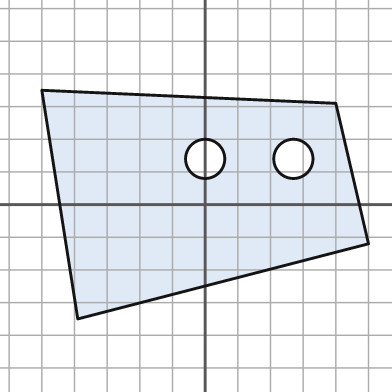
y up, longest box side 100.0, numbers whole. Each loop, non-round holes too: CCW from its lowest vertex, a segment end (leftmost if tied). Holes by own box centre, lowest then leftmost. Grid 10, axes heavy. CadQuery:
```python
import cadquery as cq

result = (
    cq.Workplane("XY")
    .moveTo(-39.0, -35.0)
    .lineTo(50.0, -12.0)
    .lineTo(40.0, 31.0)
    .lineTo(-50.0, 35.0)
    .close()
    .moveTo(0.0, 14.0)
    .circle(6.0)
    .moveTo(27.0, 14.0)
    .circle(6.0)
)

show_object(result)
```